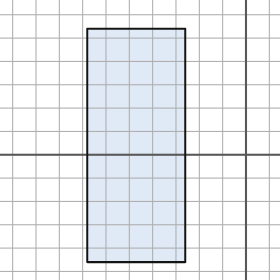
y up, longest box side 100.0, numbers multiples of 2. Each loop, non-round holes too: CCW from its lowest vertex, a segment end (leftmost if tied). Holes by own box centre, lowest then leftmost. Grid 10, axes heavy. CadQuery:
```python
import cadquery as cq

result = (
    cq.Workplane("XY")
    .moveTo(-68.0, -46.0)
    .lineTo(-26.0, -46.0)
    .lineTo(-26.0, 54.0)
    .lineTo(-68.0, 54.0)
    .close()
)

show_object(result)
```